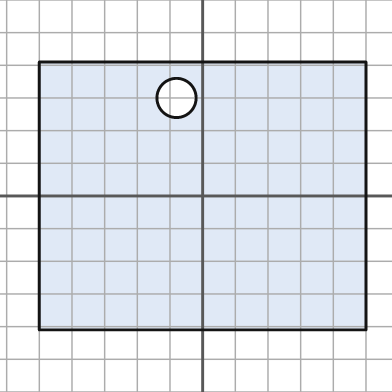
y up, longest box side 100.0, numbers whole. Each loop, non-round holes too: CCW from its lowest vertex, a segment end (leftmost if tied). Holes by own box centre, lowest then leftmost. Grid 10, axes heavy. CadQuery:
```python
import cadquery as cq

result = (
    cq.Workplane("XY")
    .moveTo(-50.0, -41.0)
    .lineTo(50.0, -41.0)
    .lineTo(50.0, 41.0)
    .lineTo(-50.0, 41.0)
    .close()
    .moveTo(-8.0, 30.0)
    .circle(6.0)
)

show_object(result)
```